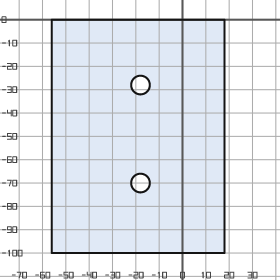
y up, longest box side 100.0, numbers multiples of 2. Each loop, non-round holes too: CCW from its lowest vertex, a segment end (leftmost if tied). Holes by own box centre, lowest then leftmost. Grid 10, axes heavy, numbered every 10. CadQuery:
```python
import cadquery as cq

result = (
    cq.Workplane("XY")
    .moveTo(-56.0, -100.0)
    .lineTo(18.0, -100.0)
    .lineTo(18.0, 0.0)
    .lineTo(-56.0, 0.0)
    .close()
    .moveTo(-18.0, -70.0)
    .circle(4.0)
    .moveTo(-18.0, -28.0)
    .circle(4.0)
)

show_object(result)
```